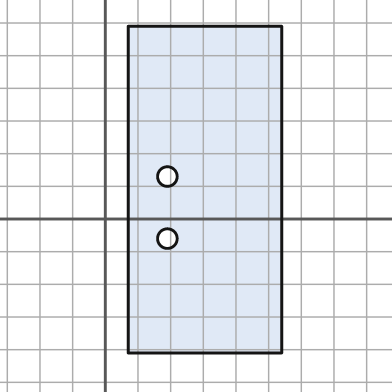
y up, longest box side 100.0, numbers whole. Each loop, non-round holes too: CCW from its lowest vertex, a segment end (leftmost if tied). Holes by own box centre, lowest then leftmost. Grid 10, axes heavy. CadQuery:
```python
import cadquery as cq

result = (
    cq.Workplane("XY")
    .moveTo(7.0, -41.0)
    .lineTo(54.0, -41.0)
    .lineTo(54.0, 59.0)
    .lineTo(7.0, 59.0)
    .close()
    .moveTo(19.0, -6.0)
    .circle(3.0)
    .moveTo(19.0, 13.0)
    .circle(3.0)
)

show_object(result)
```